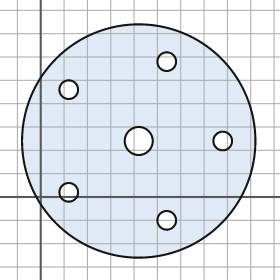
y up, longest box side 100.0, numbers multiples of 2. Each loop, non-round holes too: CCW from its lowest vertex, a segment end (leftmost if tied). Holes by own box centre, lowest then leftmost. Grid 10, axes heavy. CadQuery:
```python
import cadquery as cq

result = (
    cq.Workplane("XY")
    .moveTo(42.0, 24.0)
    .circle(50.0)
    .moveTo(54.0, -10.0)
    .circle(4.0)
    .moveTo(12.0, 2.0)
    .circle(4.0)
    .moveTo(42.0, 24.0)
    .circle(6.0)
    .moveTo(78.0, 24.0)
    .circle(4.0)
    .moveTo(12.0, 46.0)
    .circle(4.0)
    .moveTo(54.0, 58.0)
    .circle(4.0)
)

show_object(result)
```